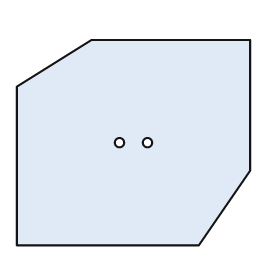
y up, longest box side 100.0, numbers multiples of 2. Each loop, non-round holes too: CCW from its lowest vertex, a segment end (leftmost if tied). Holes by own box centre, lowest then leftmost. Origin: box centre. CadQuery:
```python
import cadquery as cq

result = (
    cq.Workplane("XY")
    .moveTo(-50.0, -44.0)
    .lineTo(28.0, -44.0)
    .lineTo(50.0, -12.0)
    .lineTo(50.0, 44.0)
    .lineTo(-18.0, 44.0)
    .lineTo(-50.0, 24.0)
    .close()
    .moveTo(-6.0, 0.0)
    .circle(2.0)
    .moveTo(6.0, 0.0)
    .circle(2.0)
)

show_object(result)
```